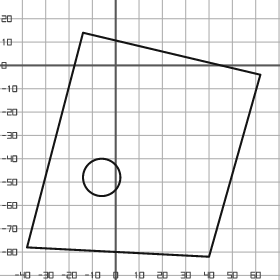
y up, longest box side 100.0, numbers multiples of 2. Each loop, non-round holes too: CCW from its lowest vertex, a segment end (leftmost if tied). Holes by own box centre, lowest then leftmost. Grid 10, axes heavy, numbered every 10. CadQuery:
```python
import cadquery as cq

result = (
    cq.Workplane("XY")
    .moveTo(40.0, -82.0)
    .lineTo(62.0, -4.0)
    .lineTo(-14.0, 14.0)
    .lineTo(-38.0, -78.0)
    .close()
    .moveTo(-6.0, -48.0)
    .circle(8.0)
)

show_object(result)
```